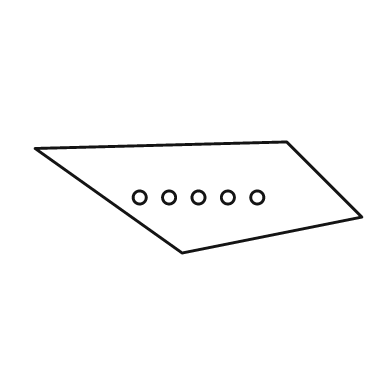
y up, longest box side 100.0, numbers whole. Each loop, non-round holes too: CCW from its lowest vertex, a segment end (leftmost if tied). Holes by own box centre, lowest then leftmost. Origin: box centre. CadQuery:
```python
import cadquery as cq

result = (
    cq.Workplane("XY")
    .moveTo(-5.0, -17.0)
    .lineTo(50.0, -6.0)
    .lineTo(27.0, 17.0)
    .lineTo(-50.0, 15.0)
    .close()
    .moveTo(-18.0, 0.0)
    .circle(2.0)
    .moveTo(-9.0, 0.0)
    .circle(2.0)
    .moveTo(0.0, 0.0)
    .circle(2.0)
    .moveTo(9.0, 0.0)
    .circle(2.0)
    .moveTo(18.0, 0.0)
    .circle(2.0)
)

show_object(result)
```